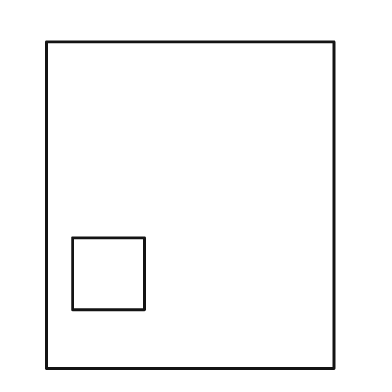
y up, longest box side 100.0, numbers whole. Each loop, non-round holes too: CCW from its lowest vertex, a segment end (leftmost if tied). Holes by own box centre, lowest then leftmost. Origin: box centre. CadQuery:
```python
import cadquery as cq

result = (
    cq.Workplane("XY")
    .moveTo(-44.0, -50.0)
    .lineTo(44.0, -50.0)
    .lineTo(44.0, 50.0)
    .lineTo(-44.0, 50.0)
    .close()
    .moveTo(-36.0, -32.0)
    .lineTo(-14.0, -32.0)
    .lineTo(-14.0, -10.0)
    .lineTo(-36.0, -10.0)
    .close()
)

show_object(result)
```